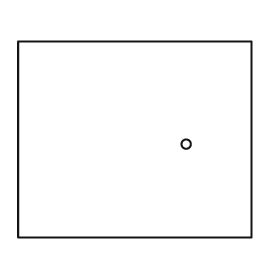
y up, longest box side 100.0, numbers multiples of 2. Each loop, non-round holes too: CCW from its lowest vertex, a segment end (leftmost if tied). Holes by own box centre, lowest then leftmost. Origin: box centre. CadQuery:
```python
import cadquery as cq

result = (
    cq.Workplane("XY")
    .moveTo(-50.0, -42.0)
    .lineTo(50.0, -42.0)
    .lineTo(50.0, 42.0)
    .lineTo(-50.0, 42.0)
    .close()
    .moveTo(22.0, -2.0)
    .circle(2.0)
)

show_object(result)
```